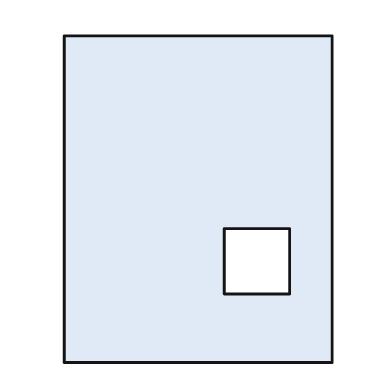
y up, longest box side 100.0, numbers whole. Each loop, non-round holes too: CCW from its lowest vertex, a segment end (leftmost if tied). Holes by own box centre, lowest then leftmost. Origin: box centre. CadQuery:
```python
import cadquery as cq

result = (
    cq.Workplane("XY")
    .moveTo(-41.0, -50.0)
    .lineTo(41.0, -50.0)
    .lineTo(41.0, 50.0)
    .lineTo(-41.0, 50.0)
    .close()
    .moveTo(8.0, -29.0)
    .lineTo(28.0, -29.0)
    .lineTo(28.0, -9.0)
    .lineTo(8.0, -9.0)
    .close()
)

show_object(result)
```